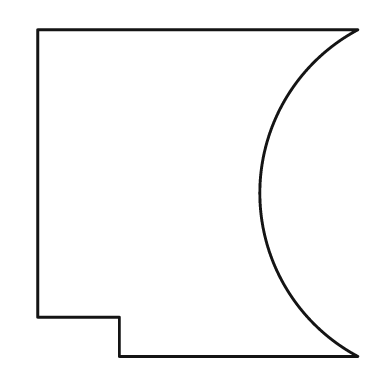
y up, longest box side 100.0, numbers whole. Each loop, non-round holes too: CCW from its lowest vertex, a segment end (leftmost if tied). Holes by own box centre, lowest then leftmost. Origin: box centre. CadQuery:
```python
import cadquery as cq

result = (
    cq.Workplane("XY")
    .moveTo(-24.0, -50.0)
    .lineTo(49.0, -50.0)
    .threePointArc((19.0, 0.0), (49.0, 50.0))
    .lineTo(-49.0, 50.0)
    .lineTo(-49.0, -38.0)
    .lineTo(-24.0, -38.0)
    .close()
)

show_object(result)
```